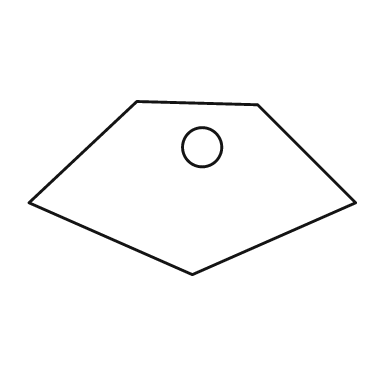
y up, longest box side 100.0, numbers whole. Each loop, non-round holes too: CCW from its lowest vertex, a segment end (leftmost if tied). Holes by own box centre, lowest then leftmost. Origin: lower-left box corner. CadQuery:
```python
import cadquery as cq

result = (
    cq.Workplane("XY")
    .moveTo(50.0, 0.0)
    .lineTo(100.0, 22.0)
    .lineTo(70.0, 52.0)
    .lineTo(33.0, 53.0)
    .lineTo(0.0, 22.0)
    .close()
    .moveTo(53.0, 39.0)
    .circle(6.0)
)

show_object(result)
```